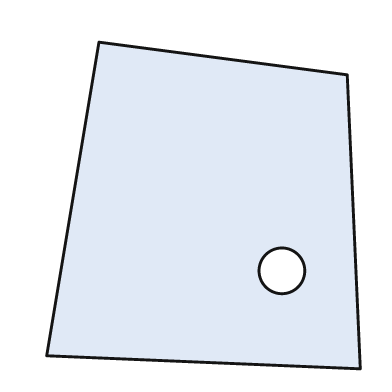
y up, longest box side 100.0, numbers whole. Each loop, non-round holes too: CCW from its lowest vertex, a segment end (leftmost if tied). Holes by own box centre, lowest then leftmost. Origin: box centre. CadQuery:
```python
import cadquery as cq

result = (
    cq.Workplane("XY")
    .moveTo(48.0, -50.0)
    .lineTo(44.0, 40.0)
    .lineTo(-32.0, 50.0)
    .lineTo(-48.0, -46.0)
    .close()
    .moveTo(24.0, -20.0)
    .circle(7.0)
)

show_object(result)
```